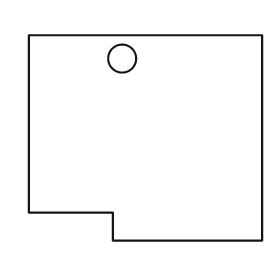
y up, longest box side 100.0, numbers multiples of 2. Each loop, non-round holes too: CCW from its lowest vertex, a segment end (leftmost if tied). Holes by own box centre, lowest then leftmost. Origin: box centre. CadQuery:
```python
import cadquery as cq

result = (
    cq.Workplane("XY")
    .moveTo(-14.0, -44.0)
    .lineTo(50.0, -44.0)
    .lineTo(50.0, 44.0)
    .lineTo(-50.0, 44.0)
    .lineTo(-50.0, -32.0)
    .lineTo(-14.0, -32.0)
    .close()
    .moveTo(-10.0, 34.0)
    .circle(6.0)
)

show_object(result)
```